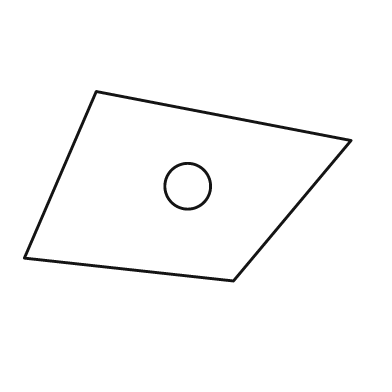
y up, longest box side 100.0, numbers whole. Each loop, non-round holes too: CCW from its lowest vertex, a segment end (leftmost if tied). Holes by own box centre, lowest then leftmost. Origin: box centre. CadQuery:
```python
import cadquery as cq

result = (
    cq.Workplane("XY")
    .moveTo(14.0, -29.0)
    .lineTo(50.0, 14.0)
    .lineTo(-28.0, 29.0)
    .lineTo(-50.0, -22.0)
    .close()
    .moveTo(0.0, 0.0)
    .circle(7.0)
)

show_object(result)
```